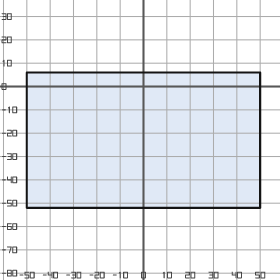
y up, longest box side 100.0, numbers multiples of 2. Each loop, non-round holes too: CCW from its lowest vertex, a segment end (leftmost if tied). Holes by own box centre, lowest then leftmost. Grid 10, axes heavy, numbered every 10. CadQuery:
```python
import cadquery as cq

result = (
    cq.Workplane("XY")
    .moveTo(-50.0, -52.0)
    .lineTo(50.0, -52.0)
    .lineTo(50.0, 6.0)
    .lineTo(-50.0, 6.0)
    .close()
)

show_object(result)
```